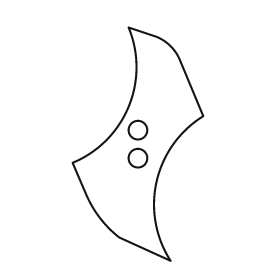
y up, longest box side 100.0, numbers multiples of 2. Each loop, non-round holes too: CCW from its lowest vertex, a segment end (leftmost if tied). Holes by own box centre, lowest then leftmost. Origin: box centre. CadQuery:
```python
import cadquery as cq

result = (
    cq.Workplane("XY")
    .moveTo(14.0, -50.0)
    .threePointArc((8.0, -16.0), (28.0, 12.0))
    .lineTo(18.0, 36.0)
    .threePointArc((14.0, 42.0), (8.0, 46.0))
    .lineTo(-4.0, 50.0)
    .threePointArc((-4.0, 16.0), (-28.0, -8.0))
    .lineTo(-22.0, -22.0)
    .threePointArc((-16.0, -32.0), (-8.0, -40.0))
    .close()
    .moveTo(0.0, -6.0)
    .circle(4.0)
    .moveTo(0.0, 6.0)
    .circle(4.0)
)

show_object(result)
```